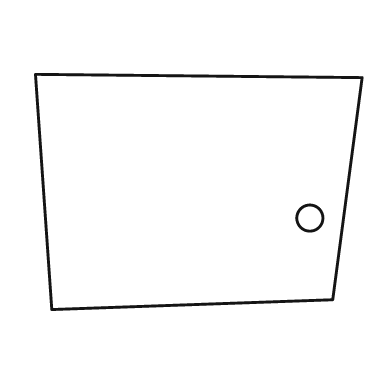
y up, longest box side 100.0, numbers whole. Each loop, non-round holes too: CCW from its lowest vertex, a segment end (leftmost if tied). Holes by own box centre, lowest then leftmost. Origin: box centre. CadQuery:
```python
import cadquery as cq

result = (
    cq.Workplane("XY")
    .moveTo(-45.0, -36.0)
    .lineTo(41.0, -33.0)
    .lineTo(50.0, 35.0)
    .lineTo(-50.0, 36.0)
    .close()
    .moveTo(34.0, -8.0)
    .circle(4.0)
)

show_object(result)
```